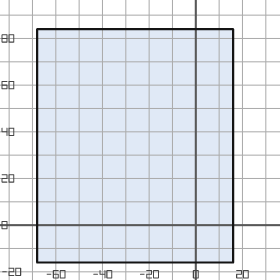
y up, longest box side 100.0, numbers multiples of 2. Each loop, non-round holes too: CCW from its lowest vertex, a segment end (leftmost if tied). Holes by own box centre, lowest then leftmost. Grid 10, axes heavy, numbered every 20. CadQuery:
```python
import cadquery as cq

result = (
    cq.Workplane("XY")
    .moveTo(-68.0, -16.0)
    .lineTo(16.0, -16.0)
    .lineTo(16.0, 84.0)
    .lineTo(-68.0, 84.0)
    .close()
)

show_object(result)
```